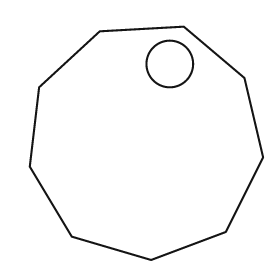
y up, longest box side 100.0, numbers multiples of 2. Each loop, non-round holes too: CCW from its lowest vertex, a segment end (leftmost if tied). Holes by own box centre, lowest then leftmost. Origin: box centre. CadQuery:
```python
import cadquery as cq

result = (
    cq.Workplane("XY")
    .moveTo(2.0, -50.0)
    .lineTo(34.0, -38.0)
    .lineTo(50.0, -6.0)
    .lineTo(42.0, 28.0)
    .lineTo(16.0, 50.0)
    .lineTo(-20.0, 48.0)
    .lineTo(-46.0, 24.0)
    .lineTo(-50.0, -10.0)
    .lineTo(-32.0, -40.0)
    .close()
    .moveTo(10.0, 34.0)
    .circle(10.0)
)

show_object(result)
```